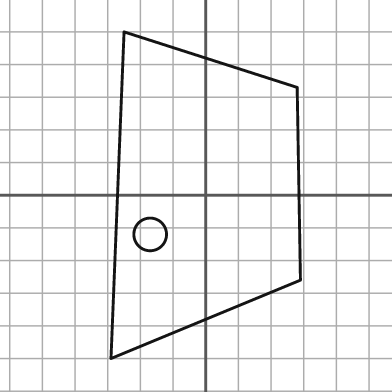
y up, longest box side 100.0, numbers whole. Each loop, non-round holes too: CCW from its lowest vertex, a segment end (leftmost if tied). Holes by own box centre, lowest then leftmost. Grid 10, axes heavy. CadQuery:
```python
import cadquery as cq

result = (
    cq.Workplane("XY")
    .moveTo(-29.0, -50.0)
    .lineTo(29.0, -26.0)
    .lineTo(28.0, 33.0)
    .lineTo(-25.0, 50.0)
    .close()
    .moveTo(-17.0, -12.0)
    .circle(5.0)
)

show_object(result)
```